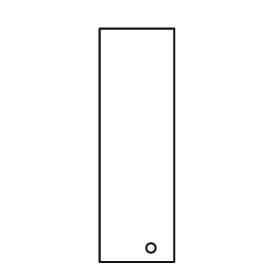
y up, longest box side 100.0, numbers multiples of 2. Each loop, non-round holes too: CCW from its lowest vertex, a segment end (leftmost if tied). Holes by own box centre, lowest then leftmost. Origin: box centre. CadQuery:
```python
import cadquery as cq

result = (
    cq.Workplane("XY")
    .moveTo(-16.0, -50.0)
    .lineTo(16.0, -50.0)
    .lineTo(16.0, 50.0)
    .lineTo(-16.0, 50.0)
    .close()
    .moveTo(6.0, -44.0)
    .circle(2.0)
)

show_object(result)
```